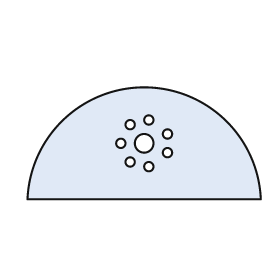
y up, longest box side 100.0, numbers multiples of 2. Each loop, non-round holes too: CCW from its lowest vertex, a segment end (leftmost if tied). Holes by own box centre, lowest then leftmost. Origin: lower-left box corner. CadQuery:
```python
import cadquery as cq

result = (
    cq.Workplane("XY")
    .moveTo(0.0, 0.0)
    .lineTo(100.0, 0.0)
    .threePointArc((50.0, 48.0), (0.0, 0.0))
    .close()
    .moveTo(52.0, 14.0)
    .circle(2.0)
    .moveTo(44.0, 16.0)
    .circle(2.0)
    .moveTo(60.0, 20.0)
    .circle(2.0)
    .moveTo(40.0, 24.0)
    .circle(2.0)
    .moveTo(50.0, 24.0)
    .circle(4.0)
    .moveTo(60.0, 28.0)
    .circle(2.0)
    .moveTo(44.0, 32.0)
    .circle(2.0)
    .moveTo(52.0, 34.0)
    .circle(2.0)
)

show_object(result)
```